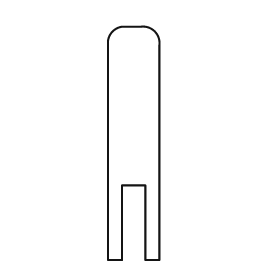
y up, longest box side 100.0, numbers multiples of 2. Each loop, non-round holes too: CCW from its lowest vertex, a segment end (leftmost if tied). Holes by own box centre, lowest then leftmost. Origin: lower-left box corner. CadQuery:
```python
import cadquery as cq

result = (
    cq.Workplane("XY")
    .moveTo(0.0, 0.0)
    .lineTo(6.0, 0.0)
    .lineTo(6.0, 32.0)
    .lineTo(16.0, 32.0)
    .lineTo(16.0, 0.0)
    .lineTo(22.0, 0.0)
    .lineTo(22.0, 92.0)
    .threePointArc((20.0, 98.0), (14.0, 100.0))
    .lineTo(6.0, 100.0)
    .threePointArc((2.0, 98.0), (0.0, 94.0))
    .close()
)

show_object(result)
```